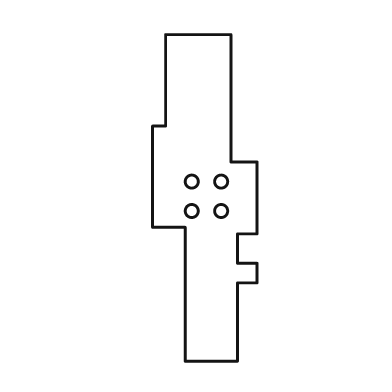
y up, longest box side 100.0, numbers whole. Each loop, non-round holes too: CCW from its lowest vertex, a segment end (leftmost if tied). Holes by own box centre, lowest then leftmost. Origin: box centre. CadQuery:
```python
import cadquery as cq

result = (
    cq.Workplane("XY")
    .moveTo(-6.0, -50.0)
    .lineTo(10.0, -50.0)
    .lineTo(10.0, -26.0)
    .lineTo(16.0, -26.0)
    .lineTo(16.0, -20.0)
    .lineTo(10.0, -20.0)
    .lineTo(10.0, -11.0)
    .lineTo(16.0, -11.0)
    .lineTo(16.0, 11.0)
    .lineTo(8.0, 11.0)
    .lineTo(8.0, 50.0)
    .lineTo(-12.0, 50.0)
    .lineTo(-12.0, 22.0)
    .lineTo(-16.0, 22.0)
    .lineTo(-16.0, -9.0)
    .lineTo(-6.0, -9.0)
    .close()
    .moveTo(-4.0, -4.0)
    .circle(2.0)
    .moveTo(5.0, -4.0)
    .circle(2.0)
    .moveTo(-4.0, 5.0)
    .circle(2.0)
    .moveTo(5.0, 5.0)
    .circle(2.0)
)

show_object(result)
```